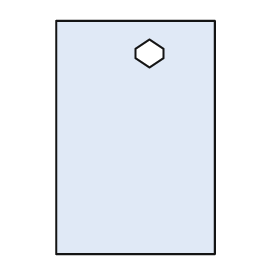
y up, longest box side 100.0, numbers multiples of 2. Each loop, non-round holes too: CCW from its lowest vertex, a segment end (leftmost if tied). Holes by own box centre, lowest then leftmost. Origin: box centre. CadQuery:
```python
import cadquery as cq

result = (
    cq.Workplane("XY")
    .moveTo(-34.0, -50.0)
    .lineTo(34.0, -50.0)
    .lineTo(34.0, 50.0)
    .lineTo(-34.0, 50.0)
    .close()
    .moveTo(6.0, 30.0)
    .lineTo(12.0, 34.0)
    .lineTo(12.0, 38.0)
    .lineTo(6.0, 42.0)
    .lineTo(0.0, 38.0)
    .lineTo(0.0, 34.0)
    .close()
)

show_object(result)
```